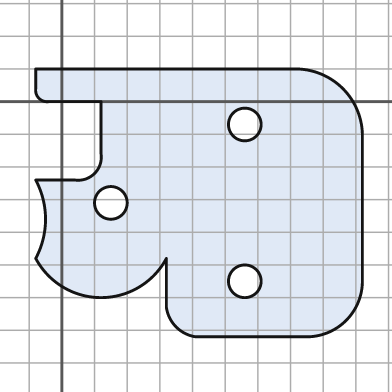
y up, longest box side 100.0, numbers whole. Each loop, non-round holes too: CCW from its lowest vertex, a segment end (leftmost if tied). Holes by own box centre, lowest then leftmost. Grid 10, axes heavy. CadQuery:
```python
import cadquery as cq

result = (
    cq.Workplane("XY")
    .moveTo(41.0, -72.0)
    .lineTo(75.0, -72.0)
    .threePointArc((87.0, -67.0), (92.0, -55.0))
    .lineTo(92.0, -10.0)
    .threePointArc((86.0, 4.0), (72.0, 10.0))
    .lineTo(-8.0, 10.0)
    .lineTo(-8.0, 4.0)
    .threePointArc((-7.0, 1.0), (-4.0, 0.0))
    .lineTo(12.0, 0.0)
    .lineTo(12.0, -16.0)
    .threePointArc((10.0, -22.0), (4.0, -24.0))
    .lineTo(-8.0, -24.0)
    .threePointArc((-5.0, -36.0), (-8.0, -48.0))
    .threePointArc((12.0, -60.0), (32.0, -48.0))
    .lineTo(32.0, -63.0)
    .threePointArc((35.0, -69.0), (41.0, -72.0))
    .close()
    .moveTo(56.0, -55.0)
    .circle(5.0)
    .moveTo(15.0, -31.0)
    .circle(5.0)
    .moveTo(56.0, -7.0)
    .circle(5.0)
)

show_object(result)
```